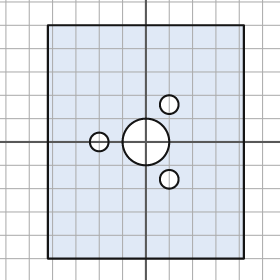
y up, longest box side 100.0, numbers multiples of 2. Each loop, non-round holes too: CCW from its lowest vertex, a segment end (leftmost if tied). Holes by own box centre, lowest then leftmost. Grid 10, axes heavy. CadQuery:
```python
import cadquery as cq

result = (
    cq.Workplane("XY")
    .moveTo(-42.0, -50.0)
    .lineTo(42.0, -50.0)
    .lineTo(42.0, 50.0)
    .lineTo(-42.0, 50.0)
    .close()
    .moveTo(10.0, -16.0)
    .circle(4.0)
    .moveTo(-20.0, 0.0)
    .circle(4.0)
    .moveTo(0.0, 0.0)
    .circle(10.0)
    .moveTo(10.0, 16.0)
    .circle(4.0)
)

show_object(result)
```